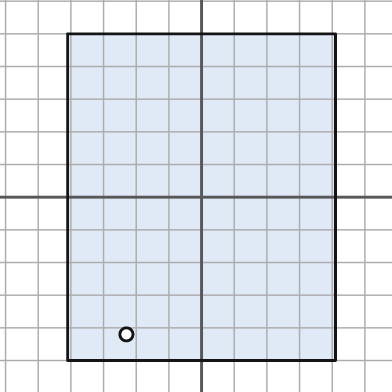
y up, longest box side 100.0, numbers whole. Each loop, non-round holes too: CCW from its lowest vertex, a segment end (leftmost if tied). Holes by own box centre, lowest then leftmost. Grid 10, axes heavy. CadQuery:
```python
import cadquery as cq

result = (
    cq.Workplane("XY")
    .moveTo(-41.0, -50.0)
    .lineTo(41.0, -50.0)
    .lineTo(41.0, 50.0)
    .lineTo(-41.0, 50.0)
    .close()
    .moveTo(-23.0, -42.0)
    .circle(2.0)
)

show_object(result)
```